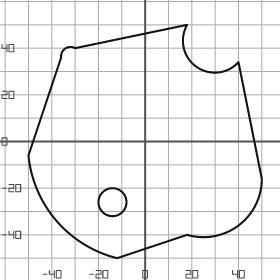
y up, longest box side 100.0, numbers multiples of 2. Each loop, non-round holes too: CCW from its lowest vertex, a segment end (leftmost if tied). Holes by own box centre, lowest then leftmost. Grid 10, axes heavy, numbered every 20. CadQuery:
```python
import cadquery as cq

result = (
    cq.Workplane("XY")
    .moveTo(-12.0, -50.0)
    .lineTo(18.0, -40.0)
    .threePointArc((40.0, -36.0), (50.0, -16.0))
    .lineTo(40.0, 34.0)
    .threePointArc((22.0, 32.0), (18.0, 50.0))
    .lineTo(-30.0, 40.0)
    .threePointArc((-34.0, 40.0), (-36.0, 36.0))
    .lineTo(-50.0, -6.0)
    .threePointArc((-38.0, -34.0), (-12.0, -50.0))
    .close()
    .moveTo(-14.0, -26.0)
    .circle(6.0)
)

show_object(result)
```